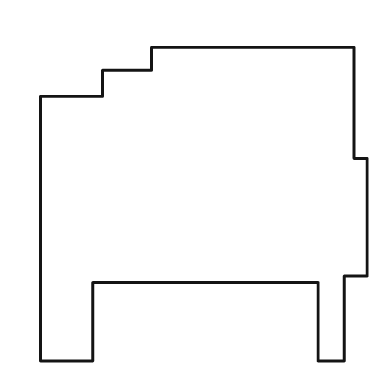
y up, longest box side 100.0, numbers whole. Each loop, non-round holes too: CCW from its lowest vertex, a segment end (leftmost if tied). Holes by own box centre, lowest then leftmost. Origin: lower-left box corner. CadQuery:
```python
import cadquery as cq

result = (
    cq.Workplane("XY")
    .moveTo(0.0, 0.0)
    .lineTo(16.0, 0.0)
    .lineTo(16.0, 24.0)
    .lineTo(85.0, 24.0)
    .lineTo(85.0, 0.0)
    .lineTo(93.0, 0.0)
    .lineTo(93.0, 26.0)
    .lineTo(100.0, 26.0)
    .lineTo(100.0, 62.0)
    .lineTo(96.0, 62.0)
    .lineTo(96.0, 96.0)
    .lineTo(34.0, 96.0)
    .lineTo(34.0, 89.0)
    .lineTo(19.0, 89.0)
    .lineTo(19.0, 81.0)
    .lineTo(0.0, 81.0)
    .close()
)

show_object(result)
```